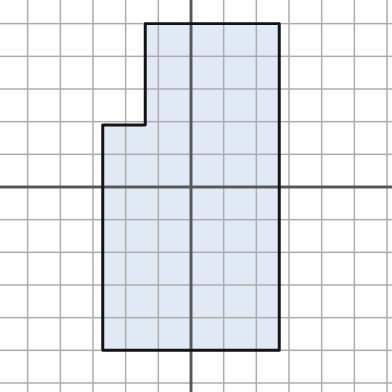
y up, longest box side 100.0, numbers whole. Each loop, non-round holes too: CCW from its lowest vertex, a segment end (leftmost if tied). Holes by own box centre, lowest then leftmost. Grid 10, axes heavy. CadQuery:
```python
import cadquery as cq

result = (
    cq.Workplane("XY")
    .moveTo(-27.0, -50.0)
    .lineTo(27.0, -50.0)
    .lineTo(27.0, 50.0)
    .lineTo(-14.0, 50.0)
    .lineTo(-14.0, 19.0)
    .lineTo(-27.0, 19.0)
    .close()
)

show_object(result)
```